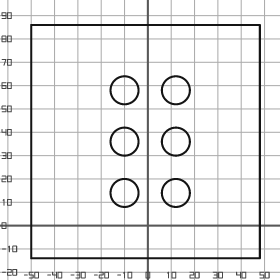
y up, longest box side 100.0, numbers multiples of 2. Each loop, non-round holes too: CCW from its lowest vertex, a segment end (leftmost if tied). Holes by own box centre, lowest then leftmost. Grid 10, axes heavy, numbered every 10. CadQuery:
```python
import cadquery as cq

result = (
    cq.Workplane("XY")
    .moveTo(-50.0, -14.0)
    .lineTo(48.0, -14.0)
    .lineTo(48.0, 86.0)
    .lineTo(-50.0, 86.0)
    .close()
    .moveTo(-10.0, 14.0)
    .circle(6.0)
    .moveTo(12.0, 14.0)
    .circle(6.0)
    .moveTo(-10.0, 36.0)
    .circle(6.0)
    .moveTo(12.0, 36.0)
    .circle(6.0)
    .moveTo(-10.0, 58.0)
    .circle(6.0)
    .moveTo(12.0, 58.0)
    .circle(6.0)
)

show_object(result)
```